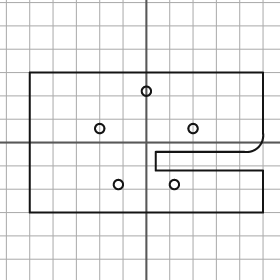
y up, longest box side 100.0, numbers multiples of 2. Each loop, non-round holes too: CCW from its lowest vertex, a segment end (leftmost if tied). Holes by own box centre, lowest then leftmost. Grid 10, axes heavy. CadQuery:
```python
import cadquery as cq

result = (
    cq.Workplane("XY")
    .moveTo(-50.0, -30.0)
    .lineTo(50.0, -30.0)
    .lineTo(50.0, -12.0)
    .lineTo(4.0, -12.0)
    .lineTo(4.0, -4.0)
    .lineTo(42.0, -4.0)
    .threePointArc((48.0, -2.0), (50.0, 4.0))
    .lineTo(50.0, 30.0)
    .lineTo(-50.0, 30.0)
    .close()
    .moveTo(-12.0, -18.0)
    .circle(2.0)
    .moveTo(12.0, -18.0)
    .circle(2.0)
    .moveTo(-20.0, 6.0)
    .circle(2.0)
    .moveTo(20.0, 6.0)
    .circle(2.0)
    .moveTo(0.0, 22.0)
    .circle(2.0)
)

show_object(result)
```